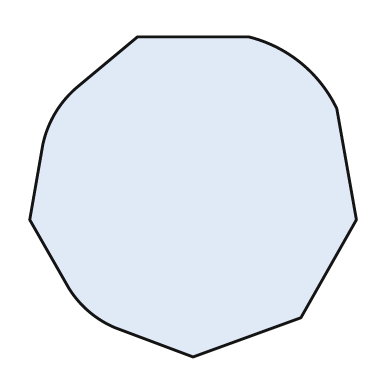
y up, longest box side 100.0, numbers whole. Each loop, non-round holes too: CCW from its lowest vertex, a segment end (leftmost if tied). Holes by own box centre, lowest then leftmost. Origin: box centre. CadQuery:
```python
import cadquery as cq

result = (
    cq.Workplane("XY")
    .moveTo(0.0, -49.0)
    .lineTo(33.0, -37.0)
    .lineTo(50.0, -7.0)
    .lineTo(44.0, 27.0)
    .threePointArc((33.0, 41.0), (17.0, 49.0))
    .lineTo(-17.0, 49.0)
    .lineTo(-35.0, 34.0)
    .threePointArc((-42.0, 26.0), (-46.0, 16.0))
    .lineTo(-50.0, -7.0)
    .lineTo(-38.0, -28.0)
    .threePointArc((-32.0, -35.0), (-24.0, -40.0))
    .close()
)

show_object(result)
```